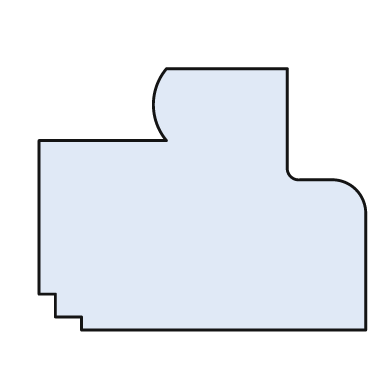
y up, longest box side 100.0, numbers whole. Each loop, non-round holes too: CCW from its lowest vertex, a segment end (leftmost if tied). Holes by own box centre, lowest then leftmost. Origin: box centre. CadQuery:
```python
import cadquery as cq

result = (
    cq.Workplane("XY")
    .moveTo(-37.0, -40.0)
    .lineTo(50.0, -40.0)
    .lineTo(50.0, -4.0)
    .threePointArc((47.0, 3.0), (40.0, 6.0))
    .lineTo(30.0, 6.0)
    .threePointArc((27.0, 7.0), (26.0, 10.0))
    .lineTo(26.0, 40.0)
    .lineTo(-11.0, 40.0)
    .threePointArc((-15.0, 29.0), (-11.0, 18.0))
    .lineTo(-50.0, 18.0)
    .lineTo(-50.0, -29.0)
    .lineTo(-45.0, -29.0)
    .lineTo(-45.0, -36.0)
    .lineTo(-37.0, -36.0)
    .close()
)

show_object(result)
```